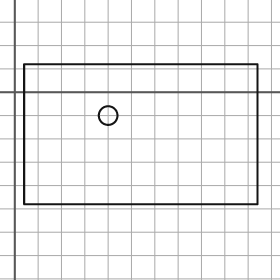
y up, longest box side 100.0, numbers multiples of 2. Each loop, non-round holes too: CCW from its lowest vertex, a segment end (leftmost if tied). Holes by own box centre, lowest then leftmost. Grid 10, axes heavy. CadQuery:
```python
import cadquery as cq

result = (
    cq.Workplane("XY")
    .moveTo(4.0, -48.0)
    .lineTo(104.0, -48.0)
    .lineTo(104.0, 12.0)
    .lineTo(4.0, 12.0)
    .close()
    .moveTo(40.0, -10.0)
    .circle(4.0)
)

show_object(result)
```